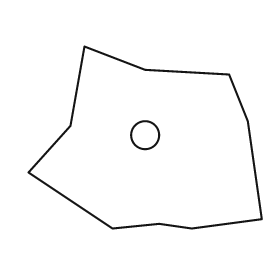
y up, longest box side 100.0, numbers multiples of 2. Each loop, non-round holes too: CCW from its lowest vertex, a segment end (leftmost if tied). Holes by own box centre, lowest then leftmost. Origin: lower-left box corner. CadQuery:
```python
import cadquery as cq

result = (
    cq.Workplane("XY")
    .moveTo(36.0, 0.0)
    .lineTo(56.0, 2.0)
    .lineTo(70.0, 0.0)
    .lineTo(100.0, 4.0)
    .lineTo(94.0, 46.0)
    .lineTo(86.0, 66.0)
    .lineTo(50.0, 68.0)
    .lineTo(24.0, 78.0)
    .lineTo(18.0, 44.0)
    .lineTo(0.0, 24.0)
    .close()
    .moveTo(50.0, 40.0)
    .circle(6.0)
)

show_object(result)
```